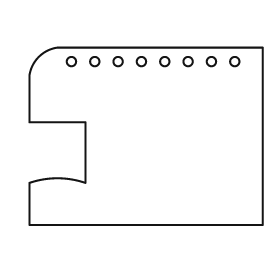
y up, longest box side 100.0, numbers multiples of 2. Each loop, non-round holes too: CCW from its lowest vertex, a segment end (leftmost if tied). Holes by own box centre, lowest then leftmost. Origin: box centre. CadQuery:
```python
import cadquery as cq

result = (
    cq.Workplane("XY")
    .moveTo(-50.0, -38.0)
    .lineTo(50.0, -38.0)
    .lineTo(50.0, 38.0)
    .lineTo(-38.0, 38.0)
    .threePointArc((-46.0, 34.0), (-50.0, 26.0))
    .lineTo(-50.0, 6.0)
    .lineTo(-26.0, 6.0)
    .lineTo(-26.0, -20.0)
    .threePointArc((-38.0, -18.0), (-50.0, -20.0))
    .close()
    .moveTo(-32.0, 32.0)
    .circle(2.0)
    .moveTo(-22.0, 32.0)
    .circle(2.0)
    .moveTo(-12.0, 32.0)
    .circle(2.0)
    .moveTo(-2.0, 32.0)
    .circle(2.0)
    .moveTo(8.0, 32.0)
    .circle(2.0)
    .moveTo(18.0, 32.0)
    .circle(2.0)
    .moveTo(28.0, 32.0)
    .circle(2.0)
    .moveTo(38.0, 32.0)
    .circle(2.0)
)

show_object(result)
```